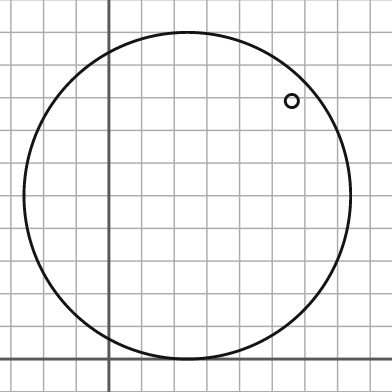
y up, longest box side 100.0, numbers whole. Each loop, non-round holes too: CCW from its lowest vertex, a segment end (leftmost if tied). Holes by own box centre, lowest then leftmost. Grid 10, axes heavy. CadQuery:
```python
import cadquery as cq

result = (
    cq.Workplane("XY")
    .moveTo(24.0, 50.0)
    .circle(50.0)
    .moveTo(56.0, 79.0)
    .circle(2.0)
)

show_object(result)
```